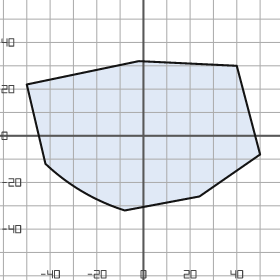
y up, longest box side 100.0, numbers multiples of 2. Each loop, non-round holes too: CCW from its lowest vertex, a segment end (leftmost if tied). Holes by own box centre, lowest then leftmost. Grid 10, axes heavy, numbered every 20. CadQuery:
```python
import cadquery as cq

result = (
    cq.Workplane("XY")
    .moveTo(-8.0, -32.0)
    .lineTo(24.0, -26.0)
    .lineTo(50.0, -8.0)
    .lineTo(40.0, 30.0)
    .lineTo(-2.0, 32.0)
    .lineTo(-50.0, 22.0)
    .lineTo(-42.0, -12.0)
    .threePointArc((-26.0, -24.0), (-8.0, -32.0))
    .close()
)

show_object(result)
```